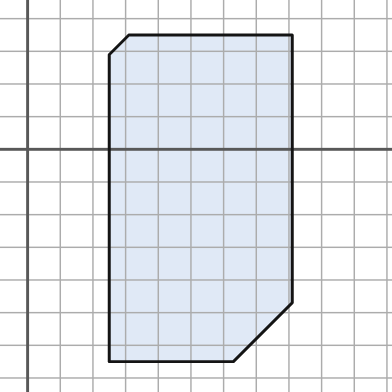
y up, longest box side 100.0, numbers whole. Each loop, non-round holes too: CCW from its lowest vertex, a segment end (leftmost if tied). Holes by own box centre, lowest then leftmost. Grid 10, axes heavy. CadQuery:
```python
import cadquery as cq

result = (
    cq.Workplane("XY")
    .moveTo(25.0, -65.0)
    .lineTo(63.0, -65.0)
    .lineTo(81.0, -47.0)
    .lineTo(81.0, 35.0)
    .lineTo(31.0, 35.0)
    .lineTo(25.0, 29.0)
    .close()
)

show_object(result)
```